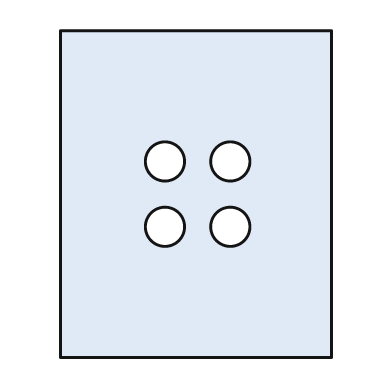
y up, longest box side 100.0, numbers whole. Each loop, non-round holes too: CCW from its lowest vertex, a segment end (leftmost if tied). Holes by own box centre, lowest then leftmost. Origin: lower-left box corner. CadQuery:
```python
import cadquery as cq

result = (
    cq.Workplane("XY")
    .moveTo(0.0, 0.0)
    .lineTo(83.0, 0.0)
    .lineTo(83.0, 100.0)
    .lineTo(0.0, 100.0)
    .close()
    .moveTo(32.0, 40.0)
    .circle(6.0)
    .moveTo(52.0, 40.0)
    .circle(6.0)
    .moveTo(32.0, 60.0)
    .circle(6.0)
    .moveTo(52.0, 60.0)
    .circle(6.0)
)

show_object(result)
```